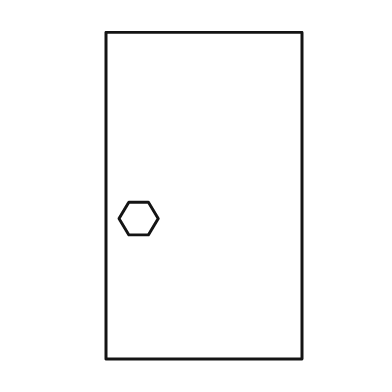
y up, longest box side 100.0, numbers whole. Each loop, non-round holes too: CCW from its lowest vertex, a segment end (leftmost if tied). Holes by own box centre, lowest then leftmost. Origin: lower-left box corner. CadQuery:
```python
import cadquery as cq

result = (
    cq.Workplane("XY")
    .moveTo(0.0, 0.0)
    .lineTo(60.0, 0.0)
    .lineTo(60.0, 100.0)
    .lineTo(0.0, 100.0)
    .close()
    .moveTo(7.0, 38.0)
    .lineTo(13.0, 38.0)
    .lineTo(16.0, 43.0)
    .lineTo(13.0, 48.0)
    .lineTo(7.0, 48.0)
    .lineTo(4.0, 43.0)
    .close()
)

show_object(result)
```